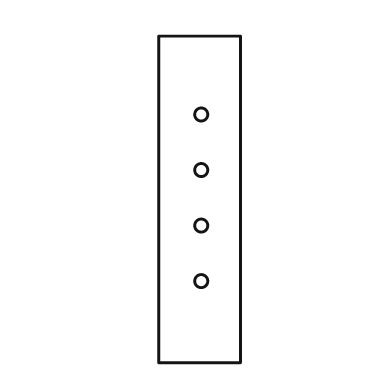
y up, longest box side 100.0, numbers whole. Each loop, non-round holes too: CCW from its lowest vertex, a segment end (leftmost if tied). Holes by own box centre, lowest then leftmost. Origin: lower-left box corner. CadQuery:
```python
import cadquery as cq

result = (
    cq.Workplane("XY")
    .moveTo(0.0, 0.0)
    .lineTo(25.0, 0.0)
    .lineTo(25.0, 100.0)
    .lineTo(0.0, 100.0)
    .close()
    .moveTo(13.0, 25.0)
    .circle(2.0)
    .moveTo(13.0, 42.0)
    .circle(2.0)
    .moveTo(13.0, 59.0)
    .circle(2.0)
    .moveTo(13.0, 76.0)
    .circle(2.0)
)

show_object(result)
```